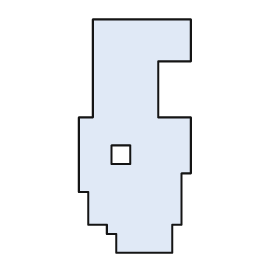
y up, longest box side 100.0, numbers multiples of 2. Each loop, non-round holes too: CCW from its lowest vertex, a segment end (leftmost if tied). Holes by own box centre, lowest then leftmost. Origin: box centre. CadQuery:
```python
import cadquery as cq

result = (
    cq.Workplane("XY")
    .moveTo(-8.0, -50.0)
    .lineTo(16.0, -50.0)
    .lineTo(16.0, -38.0)
    .lineTo(20.0, -38.0)
    .lineTo(20.0, -16.0)
    .lineTo(24.0, -16.0)
    .lineTo(24.0, 8.0)
    .lineTo(10.0, 8.0)
    .lineTo(10.0, 32.0)
    .lineTo(24.0, 32.0)
    .lineTo(24.0, 50.0)
    .lineTo(-18.0, 50.0)
    .lineTo(-18.0, 8.0)
    .lineTo(-24.0, 8.0)
    .lineTo(-24.0, -24.0)
    .lineTo(-20.0, -24.0)
    .lineTo(-20.0, -38.0)
    .lineTo(-12.0, -38.0)
    .lineTo(-12.0, -42.0)
    .lineTo(-8.0, -42.0)
    .close()
    .moveTo(-10.0, -12.0)
    .lineTo(-2.0, -12.0)
    .lineTo(-2.0, -4.0)
    .lineTo(-10.0, -4.0)
    .close()
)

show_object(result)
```